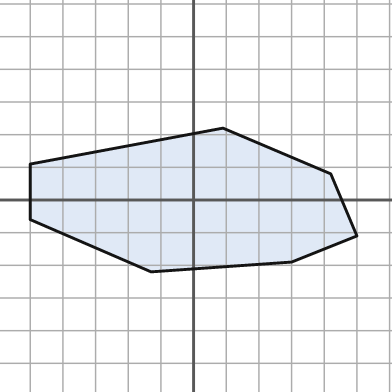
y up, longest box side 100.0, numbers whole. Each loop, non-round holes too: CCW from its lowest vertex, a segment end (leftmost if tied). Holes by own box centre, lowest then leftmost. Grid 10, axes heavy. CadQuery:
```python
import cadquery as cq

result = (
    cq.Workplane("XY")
    .moveTo(-13.0, -22.0)
    .lineTo(30.0, -19.0)
    .lineTo(50.0, -11.0)
    .lineTo(42.0, 8.0)
    .lineTo(9.0, 22.0)
    .lineTo(-50.0, 11.0)
    .lineTo(-50.0, -6.0)
    .close()
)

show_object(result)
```